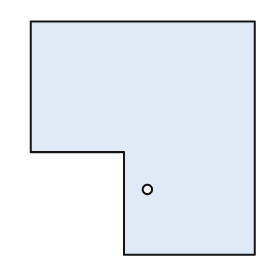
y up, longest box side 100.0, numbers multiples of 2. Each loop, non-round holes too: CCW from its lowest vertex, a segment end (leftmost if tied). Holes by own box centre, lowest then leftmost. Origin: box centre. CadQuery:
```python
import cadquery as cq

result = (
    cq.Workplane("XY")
    .moveTo(-8.0, -50.0)
    .lineTo(48.0, -50.0)
    .lineTo(48.0, 50.0)
    .lineTo(-48.0, 50.0)
    .lineTo(-48.0, -6.0)
    .lineTo(-8.0, -6.0)
    .close()
    .moveTo(2.0, -22.0)
    .circle(2.0)
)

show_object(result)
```